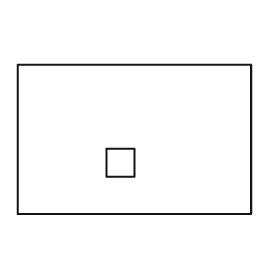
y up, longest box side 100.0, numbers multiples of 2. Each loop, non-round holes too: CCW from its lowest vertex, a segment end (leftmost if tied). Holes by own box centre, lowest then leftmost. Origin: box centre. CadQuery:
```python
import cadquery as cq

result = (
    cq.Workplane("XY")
    .moveTo(-50.0, -32.0)
    .lineTo(50.0, -32.0)
    .lineTo(50.0, 32.0)
    .lineTo(-50.0, 32.0)
    .close()
    .moveTo(-12.0, -16.0)
    .lineTo(0.0, -16.0)
    .lineTo(0.0, -4.0)
    .lineTo(-12.0, -4.0)
    .close()
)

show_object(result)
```